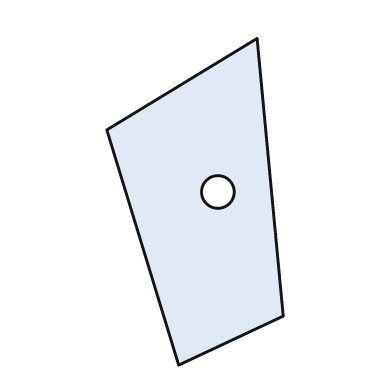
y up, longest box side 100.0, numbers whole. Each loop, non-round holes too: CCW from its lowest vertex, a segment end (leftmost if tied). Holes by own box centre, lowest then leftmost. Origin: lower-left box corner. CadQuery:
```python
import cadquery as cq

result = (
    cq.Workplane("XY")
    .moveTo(22.0, 0.0)
    .lineTo(54.0, 15.0)
    .lineTo(46.0, 100.0)
    .lineTo(0.0, 72.0)
    .close()
    .moveTo(34.0, 53.0)
    .circle(5.0)
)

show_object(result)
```